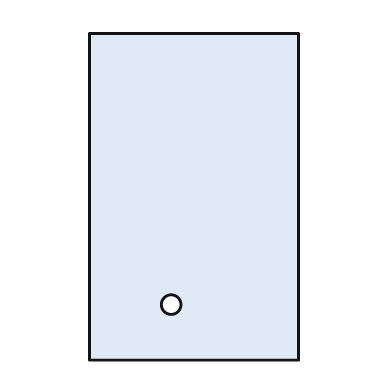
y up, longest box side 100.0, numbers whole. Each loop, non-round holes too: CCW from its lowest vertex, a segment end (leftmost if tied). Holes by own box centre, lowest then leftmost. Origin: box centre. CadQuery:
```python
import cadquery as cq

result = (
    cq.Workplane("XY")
    .moveTo(-32.0, -50.0)
    .lineTo(32.0, -50.0)
    .lineTo(32.0, 50.0)
    .lineTo(-32.0, 50.0)
    .close()
    .moveTo(-7.0, -33.0)
    .circle(3.0)
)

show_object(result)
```